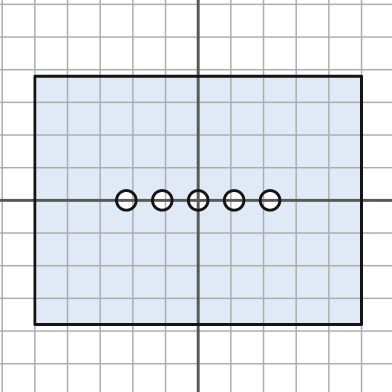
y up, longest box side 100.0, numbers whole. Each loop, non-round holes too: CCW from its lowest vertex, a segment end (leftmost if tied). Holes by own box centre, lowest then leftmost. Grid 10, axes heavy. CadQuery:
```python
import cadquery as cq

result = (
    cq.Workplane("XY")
    .moveTo(-50.0, -38.0)
    .lineTo(50.0, -38.0)
    .lineTo(50.0, 38.0)
    .lineTo(-50.0, 38.0)
    .close()
    .moveTo(-22.0, 0.0)
    .circle(3.0)
    .moveTo(-11.0, 0.0)
    .circle(3.0)
    .moveTo(0.0, 0.0)
    .circle(3.0)
    .moveTo(11.0, 0.0)
    .circle(3.0)
    .moveTo(22.0, 0.0)
    .circle(3.0)
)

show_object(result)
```